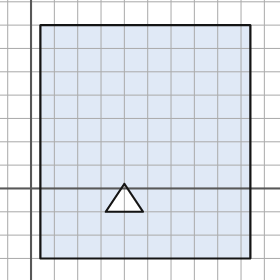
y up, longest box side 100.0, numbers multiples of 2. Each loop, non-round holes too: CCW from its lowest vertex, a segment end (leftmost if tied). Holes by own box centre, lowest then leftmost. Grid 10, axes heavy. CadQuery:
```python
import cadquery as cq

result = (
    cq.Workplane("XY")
    .moveTo(4.0, -30.0)
    .lineTo(94.0, -30.0)
    .lineTo(94.0, 70.0)
    .lineTo(4.0, 70.0)
    .close()
    .moveTo(32.0, -10.0)
    .lineTo(48.0, -10.0)
    .lineTo(40.0, 2.0)
    .close()
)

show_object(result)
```